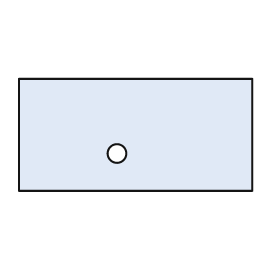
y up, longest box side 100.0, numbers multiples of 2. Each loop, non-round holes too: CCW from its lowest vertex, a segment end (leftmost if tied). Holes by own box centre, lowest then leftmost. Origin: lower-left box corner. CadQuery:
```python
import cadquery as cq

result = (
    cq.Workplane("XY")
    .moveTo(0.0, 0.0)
    .lineTo(100.0, 0.0)
    .lineTo(100.0, 48.0)
    .lineTo(0.0, 48.0)
    .close()
    .moveTo(42.0, 16.0)
    .circle(4.0)
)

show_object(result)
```